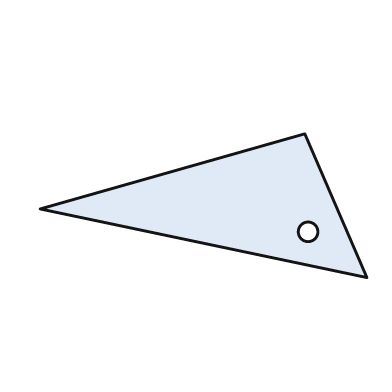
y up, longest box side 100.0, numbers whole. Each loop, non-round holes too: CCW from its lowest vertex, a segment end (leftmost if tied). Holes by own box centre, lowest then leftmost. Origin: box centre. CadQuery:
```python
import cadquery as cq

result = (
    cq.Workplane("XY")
    .moveTo(50.0, -22.0)
    .lineTo(31.0, 22.0)
    .lineTo(-50.0, -1.0)
    .close()
    .moveTo(32.0, -8.0)
    .circle(3.0)
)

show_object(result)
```